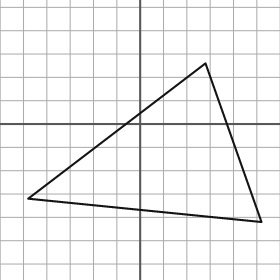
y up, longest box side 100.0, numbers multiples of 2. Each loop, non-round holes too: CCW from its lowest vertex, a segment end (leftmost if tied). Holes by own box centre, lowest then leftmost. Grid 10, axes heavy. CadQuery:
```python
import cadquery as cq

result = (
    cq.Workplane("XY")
    .moveTo(52.0, -42.0)
    .lineTo(28.0, 26.0)
    .lineTo(-48.0, -32.0)
    .close()
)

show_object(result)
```